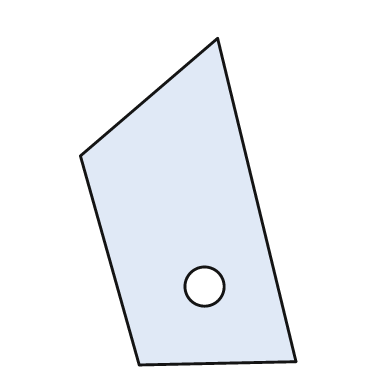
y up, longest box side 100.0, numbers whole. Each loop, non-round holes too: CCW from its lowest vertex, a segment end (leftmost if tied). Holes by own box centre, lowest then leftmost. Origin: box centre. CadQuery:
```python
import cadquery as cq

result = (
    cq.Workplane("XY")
    .moveTo(-15.0, -50.0)
    .lineTo(33.0, -49.0)
    .lineTo(9.0, 50.0)
    .lineTo(-33.0, 14.0)
    .close()
    .moveTo(5.0, -26.0)
    .circle(6.0)
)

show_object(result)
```